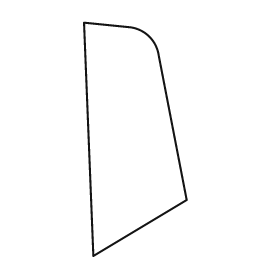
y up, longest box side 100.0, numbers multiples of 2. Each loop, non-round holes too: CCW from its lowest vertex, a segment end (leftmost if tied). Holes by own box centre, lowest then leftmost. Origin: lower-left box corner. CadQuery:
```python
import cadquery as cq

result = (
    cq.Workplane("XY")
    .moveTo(4.0, 0.0)
    .lineTo(44.0, 24.0)
    .lineTo(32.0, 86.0)
    .threePointArc((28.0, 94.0), (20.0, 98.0))
    .lineTo(0.0, 100.0)
    .close()
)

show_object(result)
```